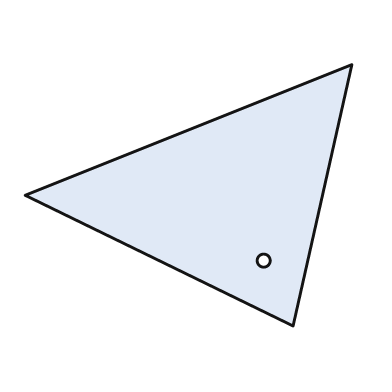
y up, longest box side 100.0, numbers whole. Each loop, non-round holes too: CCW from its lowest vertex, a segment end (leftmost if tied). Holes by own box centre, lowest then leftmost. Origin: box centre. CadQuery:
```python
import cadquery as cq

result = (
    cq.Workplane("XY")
    .moveTo(32.0, -40.0)
    .lineTo(50.0, 40.0)
    .lineTo(-50.0, 0.0)
    .close()
    .moveTo(23.0, -20.0)
    .circle(2.0)
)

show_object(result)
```